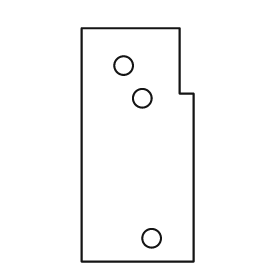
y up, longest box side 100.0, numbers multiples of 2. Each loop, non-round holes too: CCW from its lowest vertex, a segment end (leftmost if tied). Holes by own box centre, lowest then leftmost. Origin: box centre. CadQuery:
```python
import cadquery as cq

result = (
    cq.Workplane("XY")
    .moveTo(-24.0, -50.0)
    .lineTo(24.0, -50.0)
    .lineTo(24.0, 22.0)
    .lineTo(18.0, 22.0)
    .lineTo(18.0, 50.0)
    .lineTo(-24.0, 50.0)
    .close()
    .moveTo(6.0, -40.0)
    .circle(4.0)
    .moveTo(2.0, 20.0)
    .circle(4.0)
    .moveTo(-6.0, 34.0)
    .circle(4.0)
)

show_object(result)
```